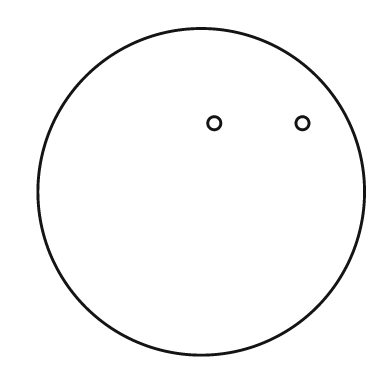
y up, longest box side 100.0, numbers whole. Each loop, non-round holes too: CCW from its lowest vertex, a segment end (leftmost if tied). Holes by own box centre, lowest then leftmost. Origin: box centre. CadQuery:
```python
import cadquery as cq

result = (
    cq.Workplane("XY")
    .moveTo(0.0, 0.0)
    .circle(50.0)
    .moveTo(4.0, 21.0)
    .circle(2.0)
    .moveTo(31.0, 21.0)
    .circle(2.0)
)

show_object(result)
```